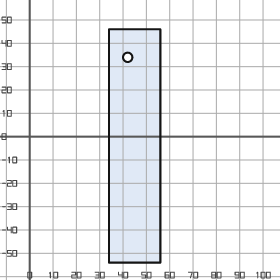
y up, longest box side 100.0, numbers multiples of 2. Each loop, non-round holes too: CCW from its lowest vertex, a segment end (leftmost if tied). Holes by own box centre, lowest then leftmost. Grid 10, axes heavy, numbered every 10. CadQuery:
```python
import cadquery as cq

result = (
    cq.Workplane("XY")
    .moveTo(34.0, -54.0)
    .lineTo(56.0, -54.0)
    .lineTo(56.0, 46.0)
    .lineTo(34.0, 46.0)
    .close()
    .moveTo(42.0, 34.0)
    .circle(2.0)
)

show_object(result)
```